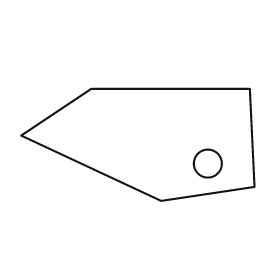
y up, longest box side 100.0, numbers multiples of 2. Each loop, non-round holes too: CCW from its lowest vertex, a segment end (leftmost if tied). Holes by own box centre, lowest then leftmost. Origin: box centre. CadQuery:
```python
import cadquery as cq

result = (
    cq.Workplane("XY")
    .moveTo(10.0, -24.0)
    .lineTo(50.0, -18.0)
    .lineTo(48.0, 24.0)
    .lineTo(-20.0, 24.0)
    .lineTo(-50.0, 4.0)
    .close()
    .moveTo(30.0, -8.0)
    .circle(6.0)
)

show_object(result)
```